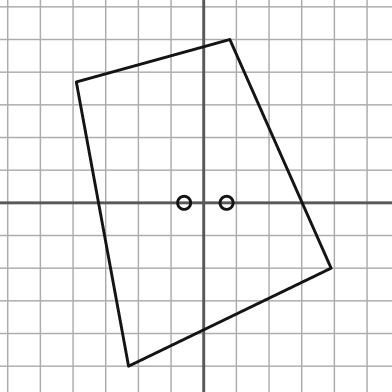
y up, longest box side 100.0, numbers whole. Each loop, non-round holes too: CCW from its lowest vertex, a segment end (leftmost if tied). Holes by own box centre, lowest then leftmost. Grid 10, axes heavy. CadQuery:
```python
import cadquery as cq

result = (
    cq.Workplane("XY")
    .moveTo(-23.0, -50.0)
    .lineTo(39.0, -20.0)
    .lineTo(8.0, 50.0)
    .lineTo(-39.0, 37.0)
    .close()
    .moveTo(-6.0, 0.0)
    .circle(2.0)
    .moveTo(7.0, 0.0)
    .circle(2.0)
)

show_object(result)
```